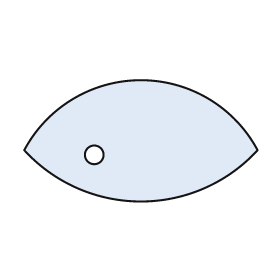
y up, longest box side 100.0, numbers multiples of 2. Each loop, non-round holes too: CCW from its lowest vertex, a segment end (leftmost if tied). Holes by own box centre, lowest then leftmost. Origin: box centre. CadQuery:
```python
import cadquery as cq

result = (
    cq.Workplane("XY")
    .moveTo(-50.0, -4.0)
    .threePointArc((0.0, -26.0), (50.0, -4.0))
    .threePointArc((0.0, 26.0), (-50.0, -4.0))
    .close()
    .moveTo(-20.0, -6.0)
    .circle(4.0)
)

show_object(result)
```